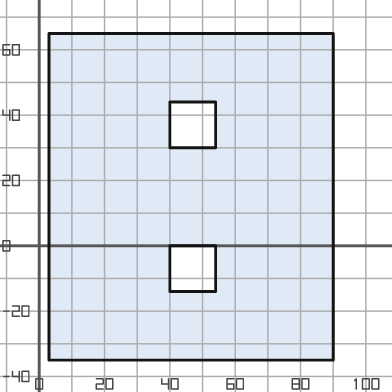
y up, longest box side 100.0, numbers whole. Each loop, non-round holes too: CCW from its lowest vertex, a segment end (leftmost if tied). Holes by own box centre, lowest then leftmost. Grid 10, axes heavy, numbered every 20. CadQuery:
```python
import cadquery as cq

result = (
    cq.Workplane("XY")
    .moveTo(3.0, -35.0)
    .lineTo(90.0, -35.0)
    .lineTo(90.0, 65.0)
    .lineTo(3.0, 65.0)
    .close()
    .moveTo(40.0, -14.0)
    .lineTo(54.0, -14.0)
    .lineTo(54.0, 0.0)
    .lineTo(40.0, 0.0)
    .close()
    .moveTo(40.0, 30.0)
    .lineTo(54.0, 30.0)
    .lineTo(54.0, 44.0)
    .lineTo(40.0, 44.0)
    .close()
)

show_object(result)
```